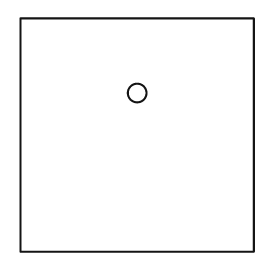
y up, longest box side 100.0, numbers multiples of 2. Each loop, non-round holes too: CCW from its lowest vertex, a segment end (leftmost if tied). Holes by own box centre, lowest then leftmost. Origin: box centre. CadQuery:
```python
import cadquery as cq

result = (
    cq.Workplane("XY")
    .moveTo(-50.0, -50.0)
    .lineTo(50.0, -50.0)
    .lineTo(50.0, 50.0)
    .lineTo(-50.0, 50.0)
    .close()
    .moveTo(0.0, 18.0)
    .circle(4.0)
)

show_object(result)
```